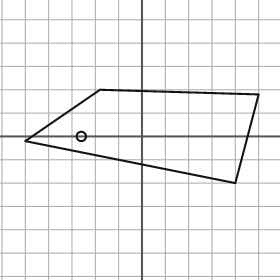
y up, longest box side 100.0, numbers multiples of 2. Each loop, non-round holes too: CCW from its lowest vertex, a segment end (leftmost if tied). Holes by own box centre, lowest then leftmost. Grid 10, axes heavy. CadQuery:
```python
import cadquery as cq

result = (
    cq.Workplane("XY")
    .moveTo(40.0, -20.0)
    .lineTo(50.0, 18.0)
    .lineTo(-18.0, 20.0)
    .lineTo(-50.0, -2.0)
    .close()
    .moveTo(-26.0, 0.0)
    .circle(2.0)
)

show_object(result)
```